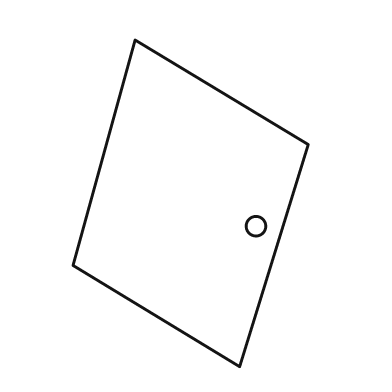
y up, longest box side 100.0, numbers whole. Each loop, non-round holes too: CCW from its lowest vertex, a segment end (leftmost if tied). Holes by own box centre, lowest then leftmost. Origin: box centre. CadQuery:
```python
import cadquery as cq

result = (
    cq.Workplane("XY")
    .moveTo(15.0, -50.0)
    .lineTo(36.0, 18.0)
    .lineTo(-17.0, 50.0)
    .lineTo(-36.0, -19.0)
    .close()
    .moveTo(20.0, -7.0)
    .circle(3.0)
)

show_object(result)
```